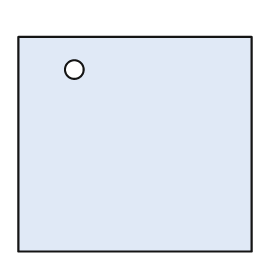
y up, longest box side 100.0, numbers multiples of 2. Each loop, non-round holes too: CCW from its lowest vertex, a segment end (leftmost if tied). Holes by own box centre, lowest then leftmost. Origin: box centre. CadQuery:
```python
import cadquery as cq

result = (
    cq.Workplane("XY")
    .moveTo(-50.0, -46.0)
    .lineTo(50.0, -46.0)
    .lineTo(50.0, 46.0)
    .lineTo(-50.0, 46.0)
    .close()
    .moveTo(-26.0, 32.0)
    .circle(4.0)
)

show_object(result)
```